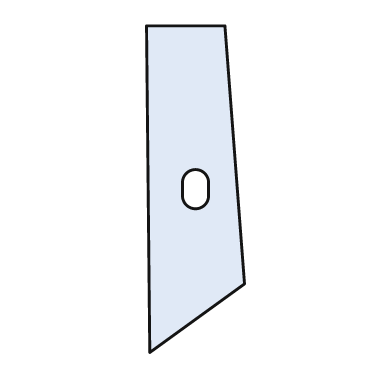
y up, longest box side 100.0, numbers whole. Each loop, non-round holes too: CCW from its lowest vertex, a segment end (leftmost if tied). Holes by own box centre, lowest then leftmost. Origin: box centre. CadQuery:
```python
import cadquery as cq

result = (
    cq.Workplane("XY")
    .moveTo(-14.0, -50.0)
    .lineTo(15.0, -29.0)
    .lineTo(9.0, 50.0)
    .lineTo(-15.0, 50.0)
    .close()
    .moveTo(-4.0, -2.0)
    .threePointArc((0.0, -6.0), (4.0, -2.0))
    .lineTo(4.0, 2.0)
    .threePointArc((0.0, 6.0), (-4.0, 2.0))
    .close()
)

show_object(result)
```